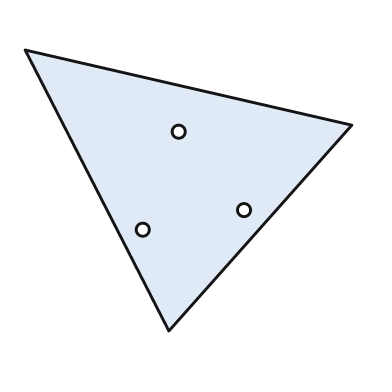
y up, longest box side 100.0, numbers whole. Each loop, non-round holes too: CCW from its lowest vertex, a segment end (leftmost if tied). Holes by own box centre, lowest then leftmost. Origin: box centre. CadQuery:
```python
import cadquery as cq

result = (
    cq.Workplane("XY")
    .moveTo(-6.0, -43.0)
    .lineTo(50.0, 20.0)
    .lineTo(-50.0, 43.0)
    .close()
    .moveTo(-14.0, -12.0)
    .circle(2.0)
    .moveTo(17.0, -6.0)
    .circle(2.0)
    .moveTo(-3.0, 18.0)
    .circle(2.0)
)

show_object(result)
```